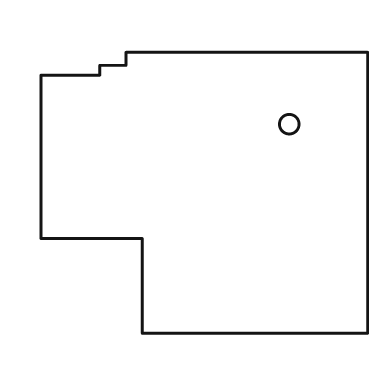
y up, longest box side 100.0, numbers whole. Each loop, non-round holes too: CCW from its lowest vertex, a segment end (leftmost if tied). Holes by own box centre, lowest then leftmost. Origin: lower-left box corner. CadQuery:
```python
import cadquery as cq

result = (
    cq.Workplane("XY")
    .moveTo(31.0, 0.0)
    .lineTo(100.0, 0.0)
    .lineTo(100.0, 86.0)
    .lineTo(26.0, 86.0)
    .lineTo(26.0, 82.0)
    .lineTo(18.0, 82.0)
    .lineTo(18.0, 79.0)
    .lineTo(0.0, 79.0)
    .lineTo(0.0, 29.0)
    .lineTo(31.0, 29.0)
    .close()
    .moveTo(76.0, 64.0)
    .circle(3.0)
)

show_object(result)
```